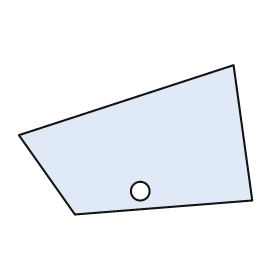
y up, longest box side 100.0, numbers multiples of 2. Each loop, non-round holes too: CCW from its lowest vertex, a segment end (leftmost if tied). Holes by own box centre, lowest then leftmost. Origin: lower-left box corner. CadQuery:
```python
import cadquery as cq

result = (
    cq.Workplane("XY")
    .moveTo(24.0, 0.0)
    .lineTo(100.0, 6.0)
    .lineTo(92.0, 64.0)
    .lineTo(0.0, 34.0)
    .close()
    .moveTo(52.0, 10.0)
    .circle(4.0)
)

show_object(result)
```